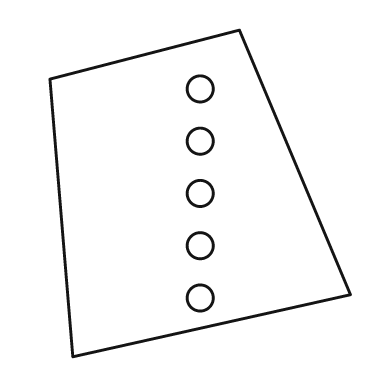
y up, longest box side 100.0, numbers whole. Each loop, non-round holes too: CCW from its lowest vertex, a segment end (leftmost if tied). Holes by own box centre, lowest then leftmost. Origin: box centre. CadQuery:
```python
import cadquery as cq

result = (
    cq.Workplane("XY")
    .moveTo(-39.0, -50.0)
    .lineTo(46.0, -31.0)
    .lineTo(12.0, 50.0)
    .lineTo(-46.0, 35.0)
    .close()
    .moveTo(0.0, -32.0)
    .circle(4.0)
    .moveTo(0.0, -16.0)
    .circle(4.0)
    .moveTo(0.0, 0.0)
    .circle(4.0)
    .moveTo(0.0, 16.0)
    .circle(4.0)
    .moveTo(0.0, 32.0)
    .circle(4.0)
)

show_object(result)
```